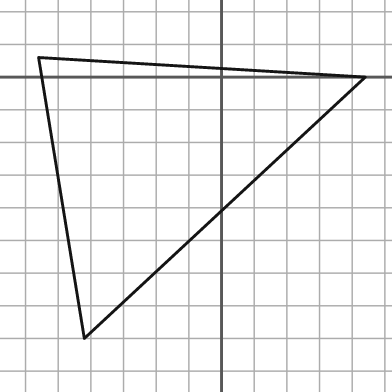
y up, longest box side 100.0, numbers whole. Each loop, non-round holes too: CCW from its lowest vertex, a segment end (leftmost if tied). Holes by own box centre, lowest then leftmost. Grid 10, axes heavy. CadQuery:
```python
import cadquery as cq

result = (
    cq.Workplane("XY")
    .moveTo(-42.0, -80.0)
    .lineTo(44.0, 0.0)
    .lineTo(-56.0, 6.0)
    .close()
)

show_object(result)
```